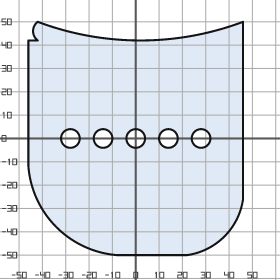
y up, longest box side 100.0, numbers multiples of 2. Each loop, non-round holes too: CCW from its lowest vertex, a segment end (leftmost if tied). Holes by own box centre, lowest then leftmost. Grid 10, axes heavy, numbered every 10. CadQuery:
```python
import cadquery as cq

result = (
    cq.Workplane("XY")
    .moveTo(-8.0, -50.0)
    .lineTo(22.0, -50.0)
    .threePointArc((38.0, -42.0), (46.0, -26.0))
    .lineTo(46.0, 50.0)
    .threePointArc((2.0, 42.0), (-42.0, 50.0))
    .threePointArc((-44.0, 46.0), (-42.0, 42.0))
    .lineTo(-46.0, 42.0)
    .lineTo(-46.0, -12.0)
    .threePointArc((-34.0, -38.0), (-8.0, -50.0))
    .close()
    .moveTo(-28.0, 0.0)
    .circle(4.0)
    .moveTo(-14.0, 0.0)
    .circle(4.0)
    .moveTo(0.0, 0.0)
    .circle(4.0)
    .moveTo(14.0, 0.0)
    .circle(4.0)
    .moveTo(28.0, 0.0)
    .circle(4.0)
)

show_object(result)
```